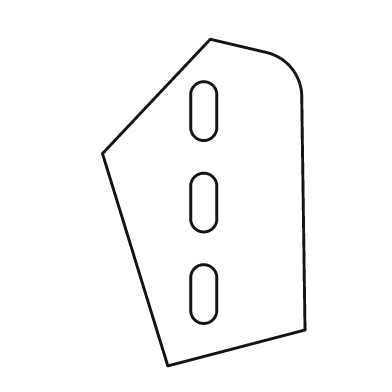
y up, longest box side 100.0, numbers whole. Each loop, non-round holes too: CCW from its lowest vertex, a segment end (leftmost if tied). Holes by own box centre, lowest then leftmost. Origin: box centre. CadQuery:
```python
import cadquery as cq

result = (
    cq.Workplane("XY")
    .moveTo(-11.0, -50.0)
    .lineTo(31.0, -39.0)
    .lineTo(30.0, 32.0)
    .threePointArc((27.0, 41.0), (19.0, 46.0))
    .lineTo(2.0, 50.0)
    .lineTo(-31.0, 15.0)
    .close()
    .moveTo(-4.0, -33.0)
    .threePointArc((0.0, -37.0), (4.0, -33.0))
    .lineTo(4.0, -23.0)
    .threePointArc((0.0, -19.0), (-4.0, -23.0))
    .close()
    .moveTo(-4.0, -5.0)
    .threePointArc((0.0, -9.0), (4.0, -5.0))
    .lineTo(4.0, 5.0)
    .threePointArc((0.0, 9.0), (-4.0, 5.0))
    .close()
    .moveTo(-4.0, 23.0)
    .threePointArc((0.0, 19.0), (4.0, 23.0))
    .lineTo(4.0, 33.0)
    .threePointArc((0.0, 37.0), (-4.0, 33.0))
    .close()
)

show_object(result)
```